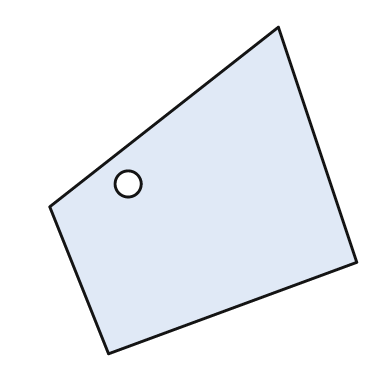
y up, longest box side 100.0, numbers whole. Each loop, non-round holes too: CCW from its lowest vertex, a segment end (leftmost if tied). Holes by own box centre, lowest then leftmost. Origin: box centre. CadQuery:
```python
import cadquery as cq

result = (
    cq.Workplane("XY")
    .moveTo(-29.0, -50.0)
    .lineTo(47.0, -22.0)
    .lineTo(23.0, 50.0)
    .lineTo(-47.0, -5.0)
    .close()
    .moveTo(-23.0, 2.0)
    .circle(4.0)
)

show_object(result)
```